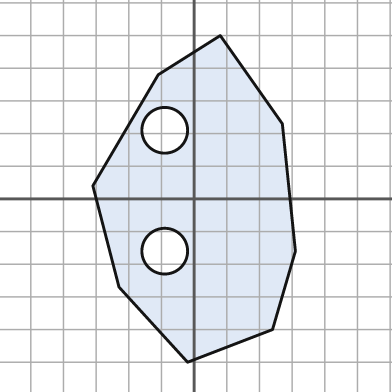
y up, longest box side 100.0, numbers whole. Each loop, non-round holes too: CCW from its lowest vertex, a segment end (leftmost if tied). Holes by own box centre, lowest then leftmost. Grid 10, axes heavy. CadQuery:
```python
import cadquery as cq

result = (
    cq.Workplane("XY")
    .moveTo(-2.0, -50.0)
    .lineTo(24.0, -40.0)
    .lineTo(31.0, -16.0)
    .lineTo(27.0, 23.0)
    .lineTo(8.0, 50.0)
    .lineTo(-11.0, 38.0)
    .lineTo(-31.0, 4.0)
    .lineTo(-23.0, -27.0)
    .close()
    .moveTo(-9.0, -16.0)
    .circle(7.0)
    .moveTo(-9.0, 21.0)
    .circle(7.0)
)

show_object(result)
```